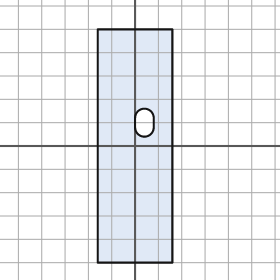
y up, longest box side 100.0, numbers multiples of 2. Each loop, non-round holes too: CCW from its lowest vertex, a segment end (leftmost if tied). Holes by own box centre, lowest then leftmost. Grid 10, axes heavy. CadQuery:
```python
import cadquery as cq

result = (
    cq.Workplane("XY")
    .moveTo(-16.0, -50.0)
    .lineTo(16.0, -50.0)
    .lineTo(16.0, 50.0)
    .lineTo(-16.0, 50.0)
    .close()
    .moveTo(0.0, 8.0)
    .threePointArc((4.0, 4.0), (8.0, 8.0))
    .lineTo(8.0, 12.0)
    .threePointArc((4.0, 16.0), (0.0, 12.0))
    .close()
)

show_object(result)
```